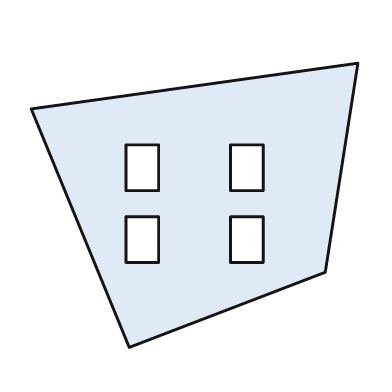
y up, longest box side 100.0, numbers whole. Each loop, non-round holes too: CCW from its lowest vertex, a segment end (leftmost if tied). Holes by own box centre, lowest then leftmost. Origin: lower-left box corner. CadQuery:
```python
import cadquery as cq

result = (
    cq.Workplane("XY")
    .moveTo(30.0, 0.0)
    .lineTo(90.0, 23.0)
    .lineTo(100.0, 87.0)
    .lineTo(0.0, 73.0)
    .close()
    .moveTo(29.0, 26.0)
    .lineTo(39.0, 26.0)
    .lineTo(39.0, 40.0)
    .lineTo(29.0, 40.0)
    .close()
    .moveTo(61.0, 26.0)
    .lineTo(71.0, 26.0)
    .lineTo(71.0, 40.0)
    .lineTo(61.0, 40.0)
    .close()
    .moveTo(29.0, 48.0)
    .lineTo(39.0, 48.0)
    .lineTo(39.0, 62.0)
    .lineTo(29.0, 62.0)
    .close()
    .moveTo(61.0, 48.0)
    .lineTo(71.0, 48.0)
    .lineTo(71.0, 62.0)
    .lineTo(61.0, 62.0)
    .close()
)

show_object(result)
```